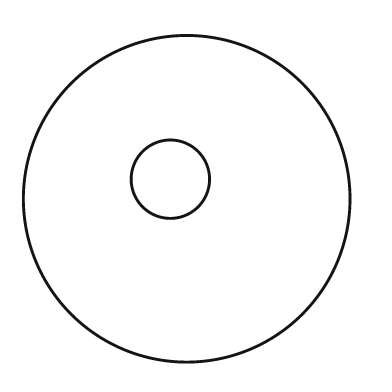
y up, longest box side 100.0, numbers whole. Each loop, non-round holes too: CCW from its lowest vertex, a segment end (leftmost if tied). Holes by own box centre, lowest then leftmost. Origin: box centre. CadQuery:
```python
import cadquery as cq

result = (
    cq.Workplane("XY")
    .moveTo(0.0, 0.0)
    .circle(50.0)
    .moveTo(-5.0, 6.0)
    .circle(12.0)
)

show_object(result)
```